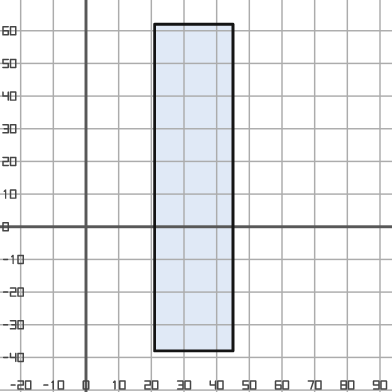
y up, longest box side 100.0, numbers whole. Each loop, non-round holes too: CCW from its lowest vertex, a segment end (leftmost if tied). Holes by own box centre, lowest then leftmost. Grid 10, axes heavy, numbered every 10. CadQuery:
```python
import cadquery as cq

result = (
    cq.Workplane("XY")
    .moveTo(21.0, -38.0)
    .lineTo(45.0, -38.0)
    .lineTo(45.0, 62.0)
    .lineTo(21.0, 62.0)
    .close()
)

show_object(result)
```